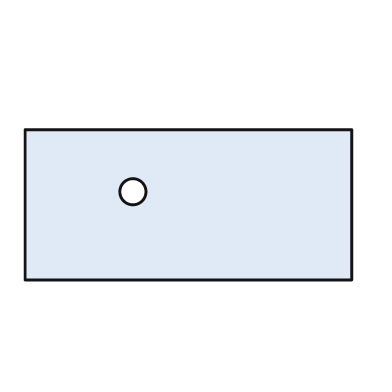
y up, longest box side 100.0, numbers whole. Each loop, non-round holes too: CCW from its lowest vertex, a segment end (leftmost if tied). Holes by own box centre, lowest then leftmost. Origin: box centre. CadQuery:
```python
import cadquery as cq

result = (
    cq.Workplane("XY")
    .moveTo(-50.0, -23.0)
    .lineTo(50.0, -23.0)
    .lineTo(50.0, 23.0)
    .lineTo(-50.0, 23.0)
    .close()
    .moveTo(-17.0, 4.0)
    .circle(4.0)
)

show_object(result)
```